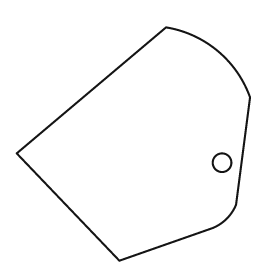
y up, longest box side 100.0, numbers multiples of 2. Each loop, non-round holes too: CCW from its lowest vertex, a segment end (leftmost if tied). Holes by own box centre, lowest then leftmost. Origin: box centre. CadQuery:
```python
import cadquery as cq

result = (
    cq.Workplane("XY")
    .moveTo(-6.0, -50.0)
    .lineTo(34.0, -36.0)
    .threePointArc((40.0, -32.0), (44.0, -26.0))
    .lineTo(50.0, 20.0)
    .threePointArc((36.0, 40.0), (14.0, 50.0))
    .lineTo(-50.0, -4.0)
    .close()
    .moveTo(38.0, -8.0)
    .circle(4.0)
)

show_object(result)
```